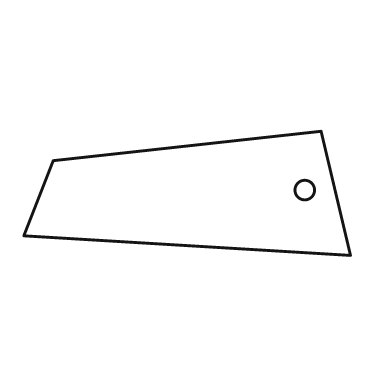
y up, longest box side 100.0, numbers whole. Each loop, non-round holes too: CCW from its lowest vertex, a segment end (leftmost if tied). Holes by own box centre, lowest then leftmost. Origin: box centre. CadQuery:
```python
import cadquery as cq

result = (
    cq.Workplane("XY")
    .moveTo(50.0, -19.0)
    .lineTo(41.0, 19.0)
    .lineTo(-41.0, 10.0)
    .lineTo(-50.0, -13.0)
    .close()
    .moveTo(36.0, 1.0)
    .circle(3.0)
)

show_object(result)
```